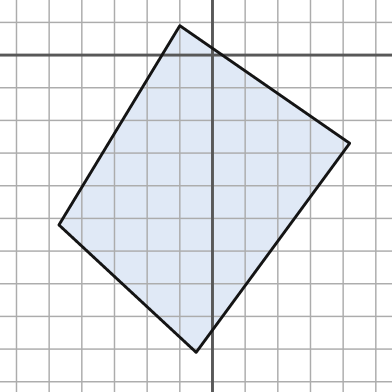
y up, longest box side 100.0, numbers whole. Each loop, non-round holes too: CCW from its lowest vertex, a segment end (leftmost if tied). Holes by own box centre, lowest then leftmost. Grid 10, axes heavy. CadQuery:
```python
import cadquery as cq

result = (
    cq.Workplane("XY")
    .moveTo(-5.0, -91.0)
    .lineTo(42.0, -27.0)
    .lineTo(-10.0, 9.0)
    .lineTo(-47.0, -52.0)
    .close()
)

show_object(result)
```